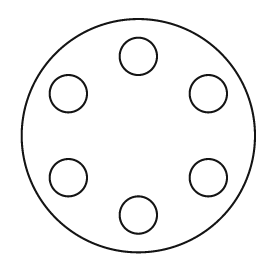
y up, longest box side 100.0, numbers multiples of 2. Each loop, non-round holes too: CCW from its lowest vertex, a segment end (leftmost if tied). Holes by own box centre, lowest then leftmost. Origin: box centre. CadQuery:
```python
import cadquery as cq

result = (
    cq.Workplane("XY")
    .moveTo(0.0, 0.0)
    .circle(50.0)
    .moveTo(0.0, -34.0)
    .circle(8.0)
    .moveTo(-30.0, -18.0)
    .circle(8.0)
    .moveTo(30.0, -18.0)
    .circle(8.0)
    .moveTo(-30.0, 18.0)
    .circle(8.0)
    .moveTo(30.0, 18.0)
    .circle(8.0)
    .moveTo(0.0, 34.0)
    .circle(8.0)
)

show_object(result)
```